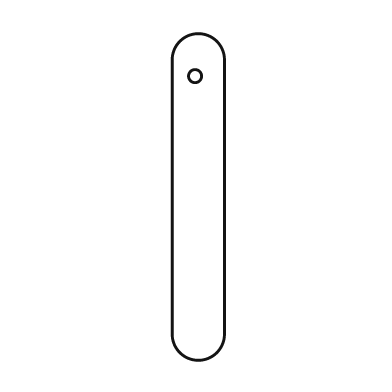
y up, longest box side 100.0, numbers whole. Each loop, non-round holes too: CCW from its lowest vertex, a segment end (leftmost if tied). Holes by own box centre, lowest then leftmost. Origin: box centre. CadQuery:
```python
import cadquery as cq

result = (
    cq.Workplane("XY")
    .moveTo(-8.0, -42.0)
    .threePointArc((0.0, -50.0), (8.0, -42.0))
    .lineTo(8.0, 42.0)
    .threePointArc((0.0, 50.0), (-8.0, 42.0))
    .close()
    .moveTo(-1.0, 37.0)
    .circle(2.0)
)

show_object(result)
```